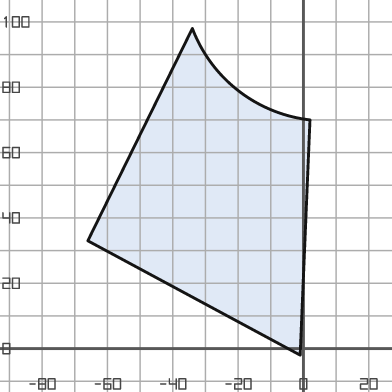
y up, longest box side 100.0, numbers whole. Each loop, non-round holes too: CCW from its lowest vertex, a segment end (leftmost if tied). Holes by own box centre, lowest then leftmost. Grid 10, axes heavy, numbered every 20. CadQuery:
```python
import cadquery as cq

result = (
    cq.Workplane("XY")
    .moveTo(-1.0, -2.0)
    .lineTo(2.0, 70.0)
    .threePointArc((-20.0, 79.0), (-34.0, 98.0))
    .lineTo(-66.0, 33.0)
    .close()
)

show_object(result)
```